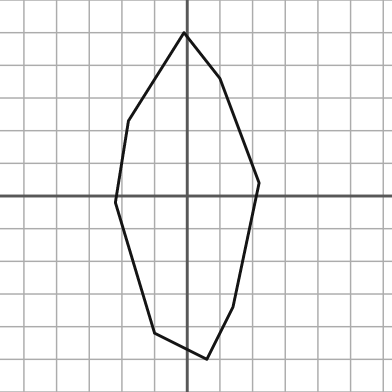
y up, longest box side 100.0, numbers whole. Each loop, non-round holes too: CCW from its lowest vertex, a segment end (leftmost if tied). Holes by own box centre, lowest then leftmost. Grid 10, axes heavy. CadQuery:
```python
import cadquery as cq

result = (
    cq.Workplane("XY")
    .moveTo(6.0, -50.0)
    .lineTo(14.0, -34.0)
    .lineTo(22.0, 4.0)
    .lineTo(10.0, 36.0)
    .lineTo(-1.0, 50.0)
    .lineTo(-18.0, 23.0)
    .lineTo(-22.0, -2.0)
    .lineTo(-10.0, -42.0)
    .close()
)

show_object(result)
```